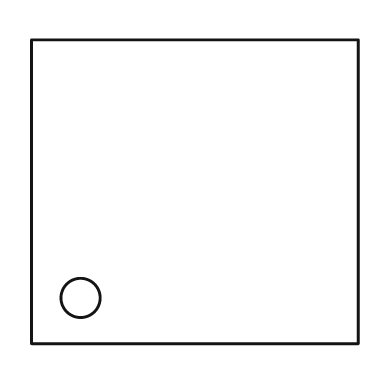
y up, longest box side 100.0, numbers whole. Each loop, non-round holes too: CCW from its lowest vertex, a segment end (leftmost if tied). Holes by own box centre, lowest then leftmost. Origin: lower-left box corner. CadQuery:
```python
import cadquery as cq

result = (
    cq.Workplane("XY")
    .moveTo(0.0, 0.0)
    .lineTo(100.0, 0.0)
    .lineTo(100.0, 93.0)
    .lineTo(0.0, 93.0)
    .close()
    .moveTo(15.0, 14.0)
    .circle(6.0)
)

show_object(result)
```